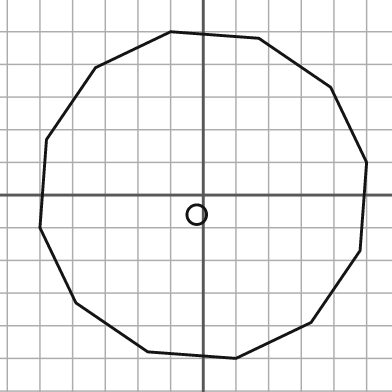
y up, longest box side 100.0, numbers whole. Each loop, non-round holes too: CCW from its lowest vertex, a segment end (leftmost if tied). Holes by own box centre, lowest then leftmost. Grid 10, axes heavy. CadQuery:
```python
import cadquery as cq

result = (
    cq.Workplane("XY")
    .moveTo(10.0, -50.0)
    .lineTo(33.0, -39.0)
    .lineTo(48.0, -17.0)
    .lineTo(50.0, 10.0)
    .lineTo(39.0, 33.0)
    .lineTo(17.0, 48.0)
    .lineTo(-10.0, 50.0)
    .lineTo(-33.0, 39.0)
    .lineTo(-48.0, 17.0)
    .lineTo(-50.0, -10.0)
    .lineTo(-39.0, -33.0)
    .lineTo(-17.0, -48.0)
    .close()
    .moveTo(-2.0, -6.0)
    .circle(3.0)
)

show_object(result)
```